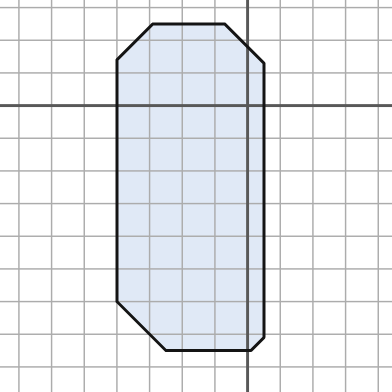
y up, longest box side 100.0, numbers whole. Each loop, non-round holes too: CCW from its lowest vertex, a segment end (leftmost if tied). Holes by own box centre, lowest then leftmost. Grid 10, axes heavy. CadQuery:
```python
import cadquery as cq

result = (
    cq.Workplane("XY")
    .moveTo(-25.0, -75.0)
    .lineTo(1.0, -75.0)
    .lineTo(5.0, -71.0)
    .lineTo(5.0, 13.0)
    .lineTo(-7.0, 25.0)
    .lineTo(-29.0, 25.0)
    .lineTo(-40.0, 14.0)
    .lineTo(-40.0, -60.0)
    .close()
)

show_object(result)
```